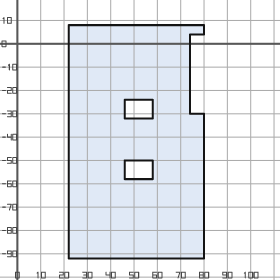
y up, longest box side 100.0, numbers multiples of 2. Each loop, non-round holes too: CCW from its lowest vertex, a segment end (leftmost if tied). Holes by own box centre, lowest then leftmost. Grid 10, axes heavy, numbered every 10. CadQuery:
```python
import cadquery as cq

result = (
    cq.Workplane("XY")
    .moveTo(22.0, -92.0)
    .lineTo(80.0, -92.0)
    .lineTo(80.0, -30.0)
    .lineTo(74.0, -30.0)
    .lineTo(74.0, 4.0)
    .lineTo(80.0, 4.0)
    .lineTo(80.0, 8.0)
    .lineTo(22.0, 8.0)
    .close()
    .moveTo(46.0, -58.0)
    .lineTo(58.0, -58.0)
    .lineTo(58.0, -50.0)
    .lineTo(46.0, -50.0)
    .close()
    .moveTo(46.0, -32.0)
    .lineTo(58.0, -32.0)
    .lineTo(58.0, -24.0)
    .lineTo(46.0, -24.0)
    .close()
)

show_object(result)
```